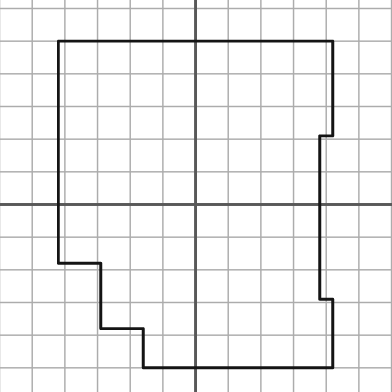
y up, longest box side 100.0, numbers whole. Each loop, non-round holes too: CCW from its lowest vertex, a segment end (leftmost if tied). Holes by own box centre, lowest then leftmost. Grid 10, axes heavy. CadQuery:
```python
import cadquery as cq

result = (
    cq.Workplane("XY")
    .moveTo(-16.0, -50.0)
    .lineTo(42.0, -50.0)
    .lineTo(42.0, -29.0)
    .lineTo(38.0, -29.0)
    .lineTo(38.0, 21.0)
    .lineTo(42.0, 21.0)
    .lineTo(42.0, 50.0)
    .lineTo(-42.0, 50.0)
    .lineTo(-42.0, -18.0)
    .lineTo(-29.0, -18.0)
    .lineTo(-29.0, -38.0)
    .lineTo(-16.0, -38.0)
    .close()
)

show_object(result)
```